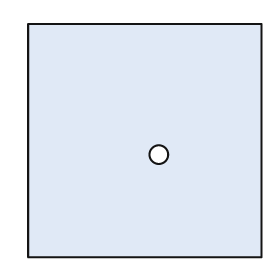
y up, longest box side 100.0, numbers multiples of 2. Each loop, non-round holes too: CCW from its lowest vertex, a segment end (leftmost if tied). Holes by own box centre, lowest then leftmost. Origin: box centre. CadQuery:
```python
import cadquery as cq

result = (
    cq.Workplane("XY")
    .moveTo(-50.0, -50.0)
    .lineTo(50.0, -50.0)
    .lineTo(50.0, 50.0)
    .lineTo(-50.0, 50.0)
    .close()
    .moveTo(6.0, -6.0)
    .circle(4.0)
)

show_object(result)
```